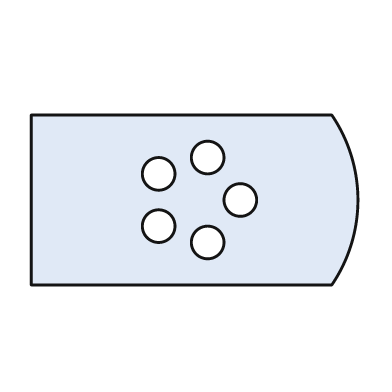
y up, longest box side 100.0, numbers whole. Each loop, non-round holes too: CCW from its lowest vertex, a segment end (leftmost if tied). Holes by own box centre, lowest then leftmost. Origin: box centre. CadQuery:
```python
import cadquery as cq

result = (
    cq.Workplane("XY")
    .moveTo(-50.0, -26.0)
    .lineTo(42.0, -26.0)
    .threePointArc((50.0, 0.0), (42.0, 26.0))
    .lineTo(-50.0, 26.0)
    .close()
    .moveTo(4.0, -13.0)
    .circle(5.0)
    .moveTo(-11.0, -8.0)
    .circle(5.0)
    .moveTo(14.0, 0.0)
    .circle(5.0)
    .moveTo(-11.0, 8.0)
    .circle(5.0)
    .moveTo(4.0, 13.0)
    .circle(5.0)
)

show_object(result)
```